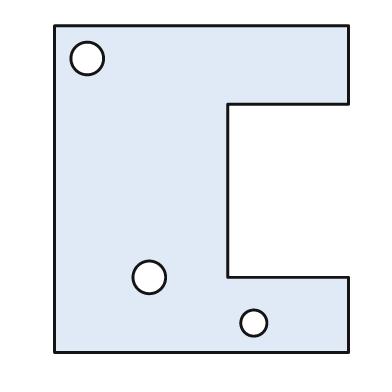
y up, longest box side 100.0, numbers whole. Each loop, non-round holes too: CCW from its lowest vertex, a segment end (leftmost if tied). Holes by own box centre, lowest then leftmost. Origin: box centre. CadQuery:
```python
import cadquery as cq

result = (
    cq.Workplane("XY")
    .moveTo(-45.0, -50.0)
    .lineTo(45.0, -50.0)
    .lineTo(45.0, -27.0)
    .lineTo(8.0, -27.0)
    .lineTo(8.0, 26.0)
    .lineTo(45.0, 26.0)
    .lineTo(45.0, 50.0)
    .lineTo(-45.0, 50.0)
    .close()
    .moveTo(16.0, -41.0)
    .circle(4.0)
    .moveTo(-16.0, -27.0)
    .circle(5.0)
    .moveTo(-35.0, 40.0)
    .circle(5.0)
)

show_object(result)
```